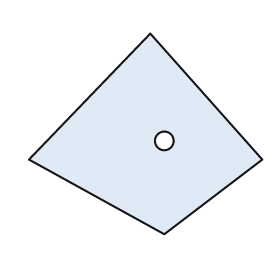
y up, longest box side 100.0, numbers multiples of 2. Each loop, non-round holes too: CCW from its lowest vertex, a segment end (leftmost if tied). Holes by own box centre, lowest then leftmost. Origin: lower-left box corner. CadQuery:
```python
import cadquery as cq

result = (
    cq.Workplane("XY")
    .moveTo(58.0, 0.0)
    .lineTo(100.0, 32.0)
    .lineTo(52.0, 86.0)
    .lineTo(0.0, 32.0)
    .close()
    .moveTo(58.0, 40.0)
    .circle(4.0)
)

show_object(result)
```